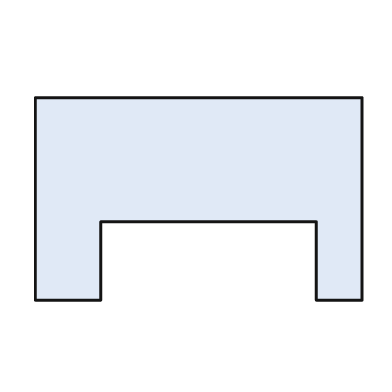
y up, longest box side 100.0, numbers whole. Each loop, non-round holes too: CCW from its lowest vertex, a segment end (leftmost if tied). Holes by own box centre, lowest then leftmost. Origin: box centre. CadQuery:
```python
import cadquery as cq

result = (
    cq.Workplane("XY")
    .moveTo(-50.0, -31.0)
    .lineTo(-30.0, -31.0)
    .lineTo(-30.0, -7.0)
    .lineTo(36.0, -7.0)
    .lineTo(36.0, -31.0)
    .lineTo(50.0, -31.0)
    .lineTo(50.0, 31.0)
    .lineTo(-50.0, 31.0)
    .close()
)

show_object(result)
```